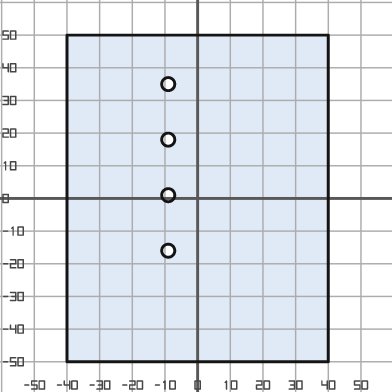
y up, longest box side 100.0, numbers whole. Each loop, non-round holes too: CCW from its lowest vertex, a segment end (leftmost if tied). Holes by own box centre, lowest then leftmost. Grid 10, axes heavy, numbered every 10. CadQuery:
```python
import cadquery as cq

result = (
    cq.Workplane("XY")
    .moveTo(-40.0, -50.0)
    .lineTo(40.0, -50.0)
    .lineTo(40.0, 50.0)
    .lineTo(-40.0, 50.0)
    .close()
    .moveTo(-9.0, -16.0)
    .circle(2.0)
    .moveTo(-9.0, 1.0)
    .circle(2.0)
    .moveTo(-9.0, 18.0)
    .circle(2.0)
    .moveTo(-9.0, 35.0)
    .circle(2.0)
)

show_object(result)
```